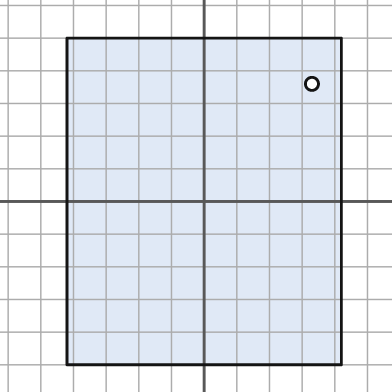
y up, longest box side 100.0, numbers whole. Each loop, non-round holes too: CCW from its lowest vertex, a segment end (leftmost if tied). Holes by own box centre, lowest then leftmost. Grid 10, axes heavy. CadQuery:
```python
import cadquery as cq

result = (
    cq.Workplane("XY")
    .moveTo(-42.0, -50.0)
    .lineTo(42.0, -50.0)
    .lineTo(42.0, 50.0)
    .lineTo(-42.0, 50.0)
    .close()
    .moveTo(33.0, 36.0)
    .circle(2.0)
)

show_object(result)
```